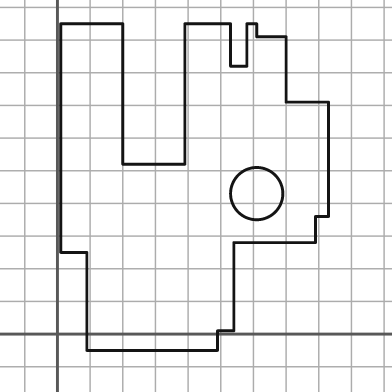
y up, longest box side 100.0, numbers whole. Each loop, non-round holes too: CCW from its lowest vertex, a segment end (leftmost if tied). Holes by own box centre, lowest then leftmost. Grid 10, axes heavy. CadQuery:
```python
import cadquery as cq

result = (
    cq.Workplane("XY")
    .moveTo(9.0, -5.0)
    .lineTo(49.0, -5.0)
    .lineTo(49.0, 1.0)
    .lineTo(54.0, 1.0)
    .lineTo(54.0, 28.0)
    .lineTo(79.0, 28.0)
    .lineTo(79.0, 36.0)
    .lineTo(83.0, 36.0)
    .lineTo(83.0, 71.0)
    .lineTo(70.0, 71.0)
    .lineTo(70.0, 91.0)
    .lineTo(61.0, 91.0)
    .lineTo(61.0, 95.0)
    .lineTo(58.0, 95.0)
    .lineTo(58.0, 82.0)
    .lineTo(53.0, 82.0)
    .lineTo(53.0, 95.0)
    .lineTo(39.0, 95.0)
    .lineTo(39.0, 52.0)
    .lineTo(20.0, 52.0)
    .lineTo(20.0, 95.0)
    .lineTo(1.0, 95.0)
    .lineTo(1.0, 25.0)
    .lineTo(9.0, 25.0)
    .close()
    .moveTo(61.0, 43.0)
    .circle(8.0)
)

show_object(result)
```